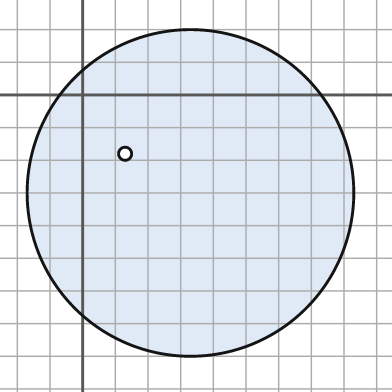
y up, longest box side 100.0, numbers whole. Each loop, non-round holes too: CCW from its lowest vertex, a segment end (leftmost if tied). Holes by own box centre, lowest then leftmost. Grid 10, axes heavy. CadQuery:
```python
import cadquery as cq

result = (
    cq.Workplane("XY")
    .moveTo(33.0, -30.0)
    .circle(50.0)
    .moveTo(13.0, -18.0)
    .circle(2.0)
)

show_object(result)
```